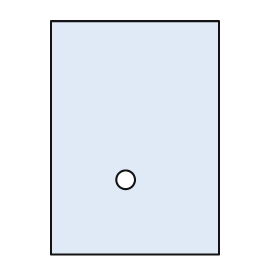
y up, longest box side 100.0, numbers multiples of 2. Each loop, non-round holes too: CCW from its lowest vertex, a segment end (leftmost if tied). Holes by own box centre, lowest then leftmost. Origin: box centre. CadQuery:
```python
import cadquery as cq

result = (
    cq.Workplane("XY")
    .moveTo(-36.0, -50.0)
    .lineTo(36.0, -50.0)
    .lineTo(36.0, 50.0)
    .lineTo(-36.0, 50.0)
    .close()
    .moveTo(-4.0, -18.0)
    .circle(4.0)
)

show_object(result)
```